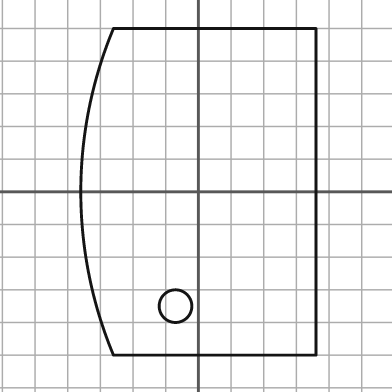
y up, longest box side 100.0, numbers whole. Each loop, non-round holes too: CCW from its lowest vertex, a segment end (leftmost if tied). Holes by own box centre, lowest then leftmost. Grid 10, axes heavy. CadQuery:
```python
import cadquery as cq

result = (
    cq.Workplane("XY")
    .moveTo(-26.0, -50.0)
    .lineTo(36.0, -50.0)
    .lineTo(36.0, 50.0)
    .lineTo(-26.0, 50.0)
    .threePointArc((-36.0, 0.0), (-26.0, -50.0))
    .close()
    .moveTo(-7.0, -35.0)
    .circle(5.0)
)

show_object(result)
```